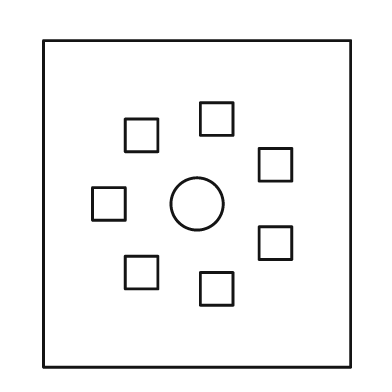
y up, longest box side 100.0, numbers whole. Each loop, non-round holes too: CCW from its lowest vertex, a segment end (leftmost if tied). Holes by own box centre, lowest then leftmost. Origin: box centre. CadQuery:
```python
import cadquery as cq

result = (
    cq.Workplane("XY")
    .moveTo(-47.0, -50.0)
    .lineTo(47.0, -50.0)
    .lineTo(47.0, 50.0)
    .lineTo(-47.0, 50.0)
    .close()
    .moveTo(1.0, -31.0)
    .lineTo(11.0, -31.0)
    .lineTo(11.0, -21.0)
    .lineTo(1.0, -21.0)
    .close()
    .moveTo(-22.0, -26.0)
    .lineTo(-12.0, -26.0)
    .lineTo(-12.0, -16.0)
    .lineTo(-22.0, -16.0)
    .close()
    .moveTo(19.0, -17.0)
    .lineTo(29.0, -17.0)
    .lineTo(29.0, -7.0)
    .lineTo(19.0, -7.0)
    .close()
    .moveTo(-32.0, -5.0)
    .lineTo(-22.0, -5.0)
    .lineTo(-22.0, 5.0)
    .lineTo(-32.0, 5.0)
    .close()
    .moveTo(0.0, 0.0)
    .circle(8.0)
    .moveTo(19.0, 7.0)
    .lineTo(29.0, 7.0)
    .lineTo(29.0, 17.0)
    .lineTo(19.0, 17.0)
    .close()
    .moveTo(-22.0, 16.0)
    .lineTo(-12.0, 16.0)
    .lineTo(-12.0, 26.0)
    .lineTo(-22.0, 26.0)
    .close()
    .moveTo(1.0, 21.0)
    .lineTo(11.0, 21.0)
    .lineTo(11.0, 31.0)
    .lineTo(1.0, 31.0)
    .close()
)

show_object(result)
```